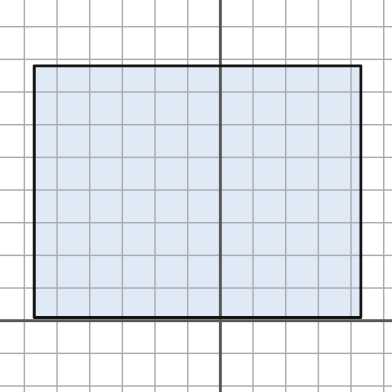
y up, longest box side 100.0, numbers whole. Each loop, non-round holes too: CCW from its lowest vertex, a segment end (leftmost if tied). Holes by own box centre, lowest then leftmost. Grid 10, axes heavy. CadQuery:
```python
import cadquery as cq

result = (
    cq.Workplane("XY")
    .moveTo(-57.0, 1.0)
    .lineTo(43.0, 1.0)
    .lineTo(43.0, 78.0)
    .lineTo(-57.0, 78.0)
    .close()
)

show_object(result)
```